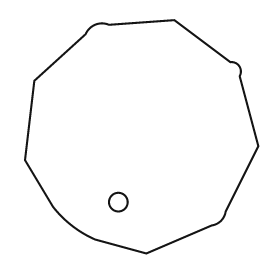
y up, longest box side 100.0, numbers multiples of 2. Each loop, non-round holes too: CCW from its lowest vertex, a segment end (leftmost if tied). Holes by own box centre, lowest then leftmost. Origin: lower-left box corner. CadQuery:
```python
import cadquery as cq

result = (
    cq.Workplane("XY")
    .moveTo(52.0, 0.0)
    .lineTo(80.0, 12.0)
    .threePointArc((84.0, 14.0), (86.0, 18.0))
    .lineTo(100.0, 46.0)
    .lineTo(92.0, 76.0)
    .threePointArc((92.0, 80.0), (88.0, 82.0))
    .lineTo(64.0, 100.0)
    .lineTo(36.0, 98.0)
    .threePointArc((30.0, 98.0), (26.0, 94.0))
    .lineTo(4.0, 74.0)
    .lineTo(0.0, 40.0)
    .lineTo(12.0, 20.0)
    .threePointArc((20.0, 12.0), (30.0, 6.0))
    .close()
    .moveTo(40.0, 22.0)
    .circle(4.0)
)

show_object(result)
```